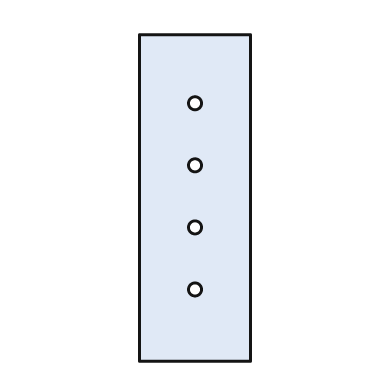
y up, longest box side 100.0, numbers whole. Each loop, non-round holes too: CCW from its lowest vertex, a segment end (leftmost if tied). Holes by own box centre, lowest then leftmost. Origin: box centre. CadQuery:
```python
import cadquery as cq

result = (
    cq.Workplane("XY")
    .moveTo(-17.0, -50.0)
    .lineTo(17.0, -50.0)
    .lineTo(17.0, 50.0)
    .lineTo(-17.0, 50.0)
    .close()
    .moveTo(0.0, -28.0)
    .circle(2.0)
    .moveTo(0.0, -9.0)
    .circle(2.0)
    .moveTo(0.0, 10.0)
    .circle(2.0)
    .moveTo(0.0, 29.0)
    .circle(2.0)
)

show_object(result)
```